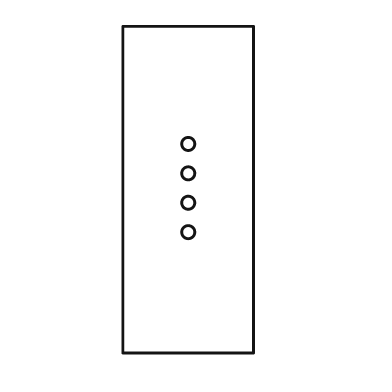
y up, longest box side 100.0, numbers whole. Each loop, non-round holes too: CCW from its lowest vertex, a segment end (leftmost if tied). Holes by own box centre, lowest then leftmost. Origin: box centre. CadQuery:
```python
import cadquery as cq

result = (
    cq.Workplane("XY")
    .moveTo(-20.0, -50.0)
    .lineTo(20.0, -50.0)
    .lineTo(20.0, 50.0)
    .lineTo(-20.0, 50.0)
    .close()
    .moveTo(0.0, -13.0)
    .circle(2.0)
    .moveTo(0.0, -4.0)
    .circle(2.0)
    .moveTo(0.0, 5.0)
    .circle(2.0)
    .moveTo(0.0, 14.0)
    .circle(2.0)
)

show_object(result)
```